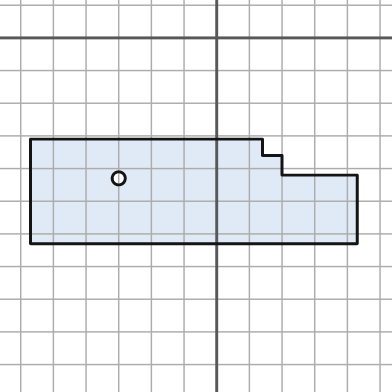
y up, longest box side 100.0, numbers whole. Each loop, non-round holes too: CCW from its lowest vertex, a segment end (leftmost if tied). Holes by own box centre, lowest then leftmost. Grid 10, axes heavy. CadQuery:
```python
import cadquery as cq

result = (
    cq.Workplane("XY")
    .moveTo(-57.0, -63.0)
    .lineTo(43.0, -63.0)
    .lineTo(43.0, -42.0)
    .lineTo(20.0, -42.0)
    .lineTo(20.0, -36.0)
    .lineTo(14.0, -36.0)
    .lineTo(14.0, -31.0)
    .lineTo(-57.0, -31.0)
    .close()
    .moveTo(-30.0, -43.0)
    .circle(2.0)
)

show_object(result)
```